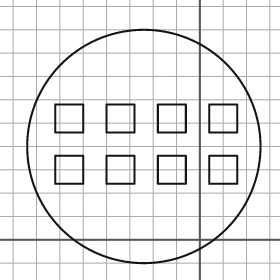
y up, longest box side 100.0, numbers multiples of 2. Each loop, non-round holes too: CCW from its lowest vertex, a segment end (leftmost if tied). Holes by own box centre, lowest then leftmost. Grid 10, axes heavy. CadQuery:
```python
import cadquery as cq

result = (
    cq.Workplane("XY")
    .moveTo(-24.0, 40.0)
    .circle(50.0)
    .moveTo(-62.0, 24.0)
    .lineTo(-50.0, 24.0)
    .lineTo(-50.0, 36.0)
    .lineTo(-62.0, 36.0)
    .close()
    .moveTo(-40.0, 24.0)
    .lineTo(-28.0, 24.0)
    .lineTo(-28.0, 36.0)
    .lineTo(-40.0, 36.0)
    .close()
    .moveTo(-18.0, 24.0)
    .lineTo(-6.0, 24.0)
    .lineTo(-6.0, 36.0)
    .lineTo(-18.0, 36.0)
    .close()
    .moveTo(4.0, 24.0)
    .lineTo(16.0, 24.0)
    .lineTo(16.0, 36.0)
    .lineTo(4.0, 36.0)
    .close()
    .moveTo(-62.0, 46.0)
    .lineTo(-50.0, 46.0)
    .lineTo(-50.0, 58.0)
    .lineTo(-62.0, 58.0)
    .close()
    .moveTo(-40.0, 46.0)
    .lineTo(-28.0, 46.0)
    .lineTo(-28.0, 58.0)
    .lineTo(-40.0, 58.0)
    .close()
    .moveTo(-18.0, 46.0)
    .lineTo(-6.0, 46.0)
    .lineTo(-6.0, 58.0)
    .lineTo(-18.0, 58.0)
    .close()
    .moveTo(4.0, 46.0)
    .lineTo(16.0, 46.0)
    .lineTo(16.0, 58.0)
    .lineTo(4.0, 58.0)
    .close()
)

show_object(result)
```